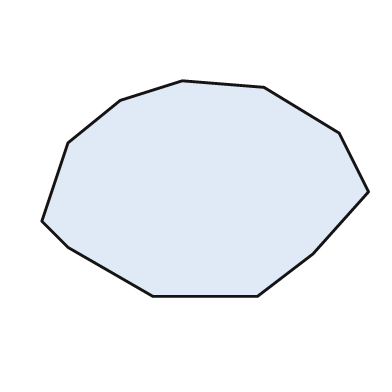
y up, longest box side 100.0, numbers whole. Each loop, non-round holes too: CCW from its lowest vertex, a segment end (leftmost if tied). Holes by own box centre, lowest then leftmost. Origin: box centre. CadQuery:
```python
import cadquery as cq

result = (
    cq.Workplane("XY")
    .moveTo(-16.0, -33.0)
    .lineTo(16.0, -33.0)
    .lineTo(33.0, -20.0)
    .lineTo(50.0, -1.0)
    .lineTo(41.0, 17.0)
    .lineTo(18.0, 31.0)
    .lineTo(-7.0, 33.0)
    .lineTo(-26.0, 27.0)
    .lineTo(-42.0, 14.0)
    .lineTo(-50.0, -10.0)
    .lineTo(-42.0, -18.0)
    .close()
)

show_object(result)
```